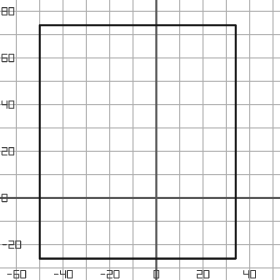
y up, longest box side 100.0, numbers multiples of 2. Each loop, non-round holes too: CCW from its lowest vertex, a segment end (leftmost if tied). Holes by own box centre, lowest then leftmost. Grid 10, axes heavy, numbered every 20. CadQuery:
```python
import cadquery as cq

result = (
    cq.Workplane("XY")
    .moveTo(-50.0, -26.0)
    .lineTo(34.0, -26.0)
    .lineTo(34.0, 74.0)
    .lineTo(-50.0, 74.0)
    .close()
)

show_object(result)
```